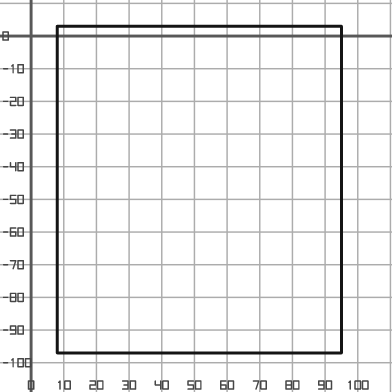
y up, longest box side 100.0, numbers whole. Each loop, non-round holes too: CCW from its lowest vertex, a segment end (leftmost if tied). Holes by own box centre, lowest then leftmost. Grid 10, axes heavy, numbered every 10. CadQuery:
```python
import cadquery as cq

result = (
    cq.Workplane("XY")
    .moveTo(8.0, -97.0)
    .lineTo(95.0, -97.0)
    .lineTo(95.0, 3.0)
    .lineTo(8.0, 3.0)
    .close()
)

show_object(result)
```